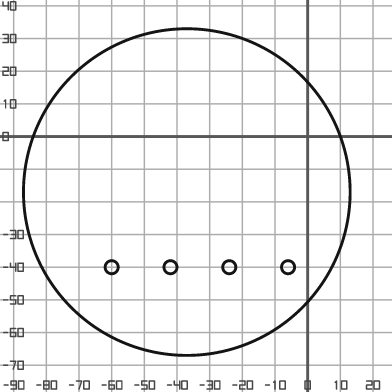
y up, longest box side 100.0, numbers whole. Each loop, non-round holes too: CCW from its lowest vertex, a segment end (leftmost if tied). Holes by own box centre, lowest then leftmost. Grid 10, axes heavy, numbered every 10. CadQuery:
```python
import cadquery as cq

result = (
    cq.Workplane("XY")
    .moveTo(-37.0, -17.0)
    .circle(50.0)
    .moveTo(-60.0, -40.0)
    .circle(2.0)
    .moveTo(-42.0, -40.0)
    .circle(2.0)
    .moveTo(-24.0, -40.0)
    .circle(2.0)
    .moveTo(-6.0, -40.0)
    .circle(2.0)
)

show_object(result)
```